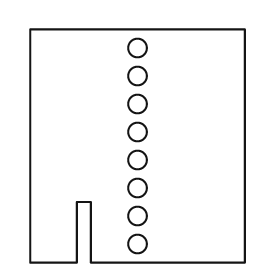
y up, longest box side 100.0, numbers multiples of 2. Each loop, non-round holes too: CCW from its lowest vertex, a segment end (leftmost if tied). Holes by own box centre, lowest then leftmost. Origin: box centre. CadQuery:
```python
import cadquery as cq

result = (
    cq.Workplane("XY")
    .moveTo(-46.0, -50.0)
    .lineTo(-26.0, -50.0)
    .lineTo(-26.0, -24.0)
    .lineTo(-20.0, -24.0)
    .lineTo(-20.0, -50.0)
    .lineTo(46.0, -50.0)
    .lineTo(46.0, 50.0)
    .lineTo(-46.0, 50.0)
    .close()
    .moveTo(0.0, -42.0)
    .circle(4.0)
    .moveTo(0.0, -30.0)
    .circle(4.0)
    .moveTo(0.0, -18.0)
    .circle(4.0)
    .moveTo(0.0, -6.0)
    .circle(4.0)
    .moveTo(0.0, 6.0)
    .circle(4.0)
    .moveTo(0.0, 18.0)
    .circle(4.0)
    .moveTo(0.0, 30.0)
    .circle(4.0)
    .moveTo(0.0, 42.0)
    .circle(4.0)
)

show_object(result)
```